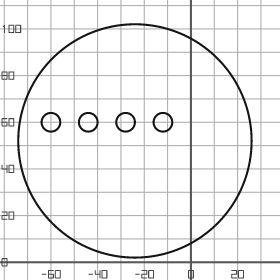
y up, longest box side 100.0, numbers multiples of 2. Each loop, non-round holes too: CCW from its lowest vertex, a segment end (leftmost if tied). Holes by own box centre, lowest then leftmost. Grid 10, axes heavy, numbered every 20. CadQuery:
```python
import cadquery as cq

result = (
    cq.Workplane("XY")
    .moveTo(-24.0, 52.0)
    .circle(50.0)
    .moveTo(-60.0, 60.0)
    .circle(4.0)
    .moveTo(-44.0, 60.0)
    .circle(4.0)
    .moveTo(-28.0, 60.0)
    .circle(4.0)
    .moveTo(-12.0, 60.0)
    .circle(4.0)
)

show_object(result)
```